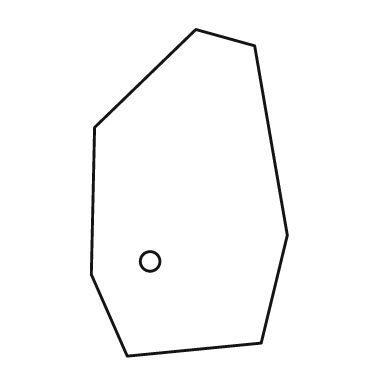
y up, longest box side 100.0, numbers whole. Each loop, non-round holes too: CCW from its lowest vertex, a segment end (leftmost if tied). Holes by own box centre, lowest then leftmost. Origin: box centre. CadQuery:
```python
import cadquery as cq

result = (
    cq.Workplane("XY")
    .moveTo(-19.0, -50.0)
    .lineTo(22.0, -46.0)
    .lineTo(30.0, -13.0)
    .lineTo(20.0, 45.0)
    .lineTo(2.0, 50.0)
    .lineTo(-29.0, 20.0)
    .lineTo(-30.0, -25.0)
    .close()
    .moveTo(-12.0, -21.0)
    .circle(3.0)
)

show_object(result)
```